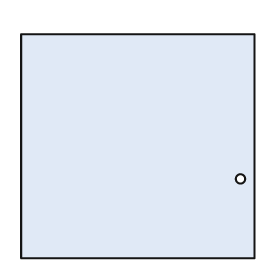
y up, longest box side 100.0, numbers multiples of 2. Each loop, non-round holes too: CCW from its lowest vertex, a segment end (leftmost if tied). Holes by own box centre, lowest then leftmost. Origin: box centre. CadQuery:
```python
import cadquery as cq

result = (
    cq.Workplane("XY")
    .moveTo(-50.0, -48.0)
    .lineTo(50.0, -48.0)
    .lineTo(50.0, 48.0)
    .lineTo(-50.0, 48.0)
    .close()
    .moveTo(44.0, -14.0)
    .circle(2.0)
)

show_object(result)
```